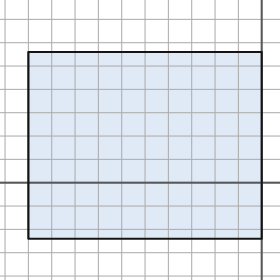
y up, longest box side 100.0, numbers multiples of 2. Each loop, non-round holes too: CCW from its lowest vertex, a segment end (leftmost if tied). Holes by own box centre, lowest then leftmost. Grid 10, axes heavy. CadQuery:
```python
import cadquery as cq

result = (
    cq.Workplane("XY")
    .moveTo(-100.0, -24.0)
    .lineTo(0.0, -24.0)
    .lineTo(0.0, 56.0)
    .lineTo(-100.0, 56.0)
    .close()
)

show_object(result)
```